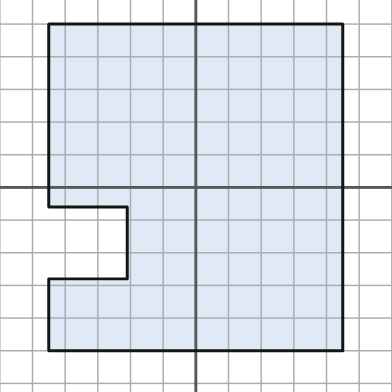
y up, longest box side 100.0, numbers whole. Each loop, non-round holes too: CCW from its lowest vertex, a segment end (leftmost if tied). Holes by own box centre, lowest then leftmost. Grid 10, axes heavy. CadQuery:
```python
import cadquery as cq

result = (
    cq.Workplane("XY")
    .moveTo(-45.0, -50.0)
    .lineTo(45.0, -50.0)
    .lineTo(45.0, 50.0)
    .lineTo(-45.0, 50.0)
    .lineTo(-45.0, -6.0)
    .lineTo(-21.0, -6.0)
    .lineTo(-21.0, -28.0)
    .lineTo(-45.0, -28.0)
    .close()
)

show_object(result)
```